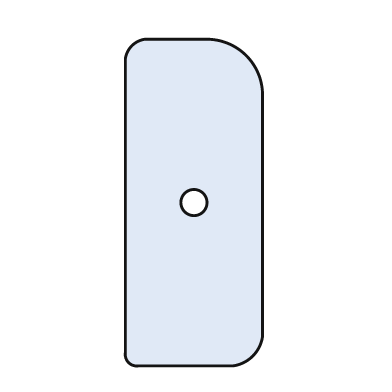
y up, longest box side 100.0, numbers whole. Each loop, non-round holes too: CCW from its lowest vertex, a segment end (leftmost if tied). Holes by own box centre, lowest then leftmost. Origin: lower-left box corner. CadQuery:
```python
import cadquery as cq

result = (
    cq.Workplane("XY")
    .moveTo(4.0, 0.0)
    .lineTo(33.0, 0.0)
    .threePointArc((39.0, 3.0), (42.0, 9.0))
    .lineTo(42.0, 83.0)
    .threePointArc((37.0, 95.0), (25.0, 100.0))
    .lineTo(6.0, 100.0)
    .threePointArc((2.0, 98.0), (0.0, 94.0))
    .lineTo(0.0, 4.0)
    .threePointArc((1.0, 1.0), (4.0, 0.0))
    .close()
    .moveTo(21.0, 50.0)
    .circle(4.0)
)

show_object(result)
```